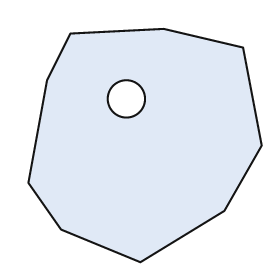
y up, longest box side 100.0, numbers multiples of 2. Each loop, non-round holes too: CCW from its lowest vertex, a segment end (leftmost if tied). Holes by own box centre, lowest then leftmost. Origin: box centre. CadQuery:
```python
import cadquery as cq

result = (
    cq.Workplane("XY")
    .moveTo(-2.0, -50.0)
    .lineTo(34.0, -28.0)
    .lineTo(50.0, 0.0)
    .lineTo(42.0, 42.0)
    .lineTo(8.0, 50.0)
    .lineTo(-32.0, 48.0)
    .lineTo(-42.0, 28.0)
    .lineTo(-50.0, -16.0)
    .lineTo(-36.0, -36.0)
    .close()
    .moveTo(-8.0, 20.0)
    .circle(8.0)
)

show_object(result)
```